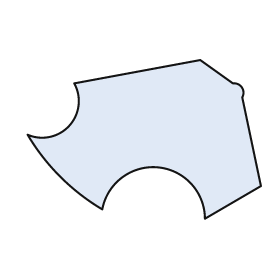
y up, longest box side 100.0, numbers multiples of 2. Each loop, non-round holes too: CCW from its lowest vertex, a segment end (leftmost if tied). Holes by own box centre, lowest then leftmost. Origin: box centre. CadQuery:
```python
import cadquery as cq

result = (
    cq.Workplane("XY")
    .moveTo(26.0, -34.0)
    .lineTo(50.0, -20.0)
    .lineTo(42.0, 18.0)
    .threePointArc((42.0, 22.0), (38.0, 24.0))
    .lineTo(24.0, 34.0)
    .lineTo(-30.0, 24.0)
    .threePointArc((-32.0, 6.0), (-50.0, 2.0))
    .threePointArc((-36.0, -16.0), (-18.0, -30.0))
    .threePointArc((6.0, -12.0), (26.0, -34.0))
    .close()
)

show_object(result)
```